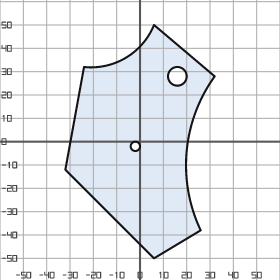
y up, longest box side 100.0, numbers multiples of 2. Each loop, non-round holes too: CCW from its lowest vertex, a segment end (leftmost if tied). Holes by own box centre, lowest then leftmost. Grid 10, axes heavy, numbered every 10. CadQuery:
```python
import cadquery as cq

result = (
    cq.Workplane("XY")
    .moveTo(6.0, -50.0)
    .lineTo(26.0, -38.0)
    .threePointArc((20.0, -4.0), (32.0, 28.0))
    .lineTo(6.0, 50.0)
    .threePointArc((-6.0, 36.0), (-24.0, 32.0))
    .lineTo(-32.0, -12.0)
    .close()
    .moveTo(-2.0, -2.0)
    .circle(2.0)
    .moveTo(16.0, 28.0)
    .circle(4.0)
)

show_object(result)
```